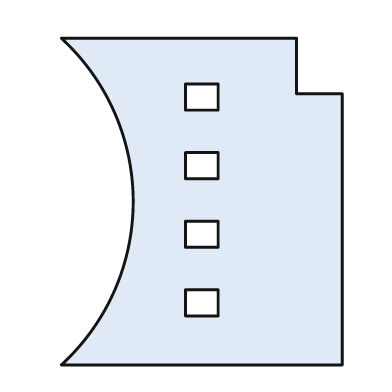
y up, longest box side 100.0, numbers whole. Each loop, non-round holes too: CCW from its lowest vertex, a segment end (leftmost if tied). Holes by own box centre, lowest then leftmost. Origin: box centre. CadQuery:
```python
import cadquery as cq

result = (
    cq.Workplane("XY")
    .moveTo(-43.0, -50.0)
    .lineTo(43.0, -50.0)
    .lineTo(43.0, 33.0)
    .lineTo(29.0, 33.0)
    .lineTo(29.0, 50.0)
    .lineTo(-43.0, 50.0)
    .threePointArc((-21.0, 0.0), (-43.0, -50.0))
    .close()
    .moveTo(-5.0, -35.0)
    .lineTo(5.0, -35.0)
    .lineTo(5.0, -27.0)
    .lineTo(-5.0, -27.0)
    .close()
    .moveTo(-5.0, -14.0)
    .lineTo(5.0, -14.0)
    .lineTo(5.0, -6.0)
    .lineTo(-5.0, -6.0)
    .close()
    .moveTo(-5.0, 7.0)
    .lineTo(5.0, 7.0)
    .lineTo(5.0, 15.0)
    .lineTo(-5.0, 15.0)
    .close()
    .moveTo(-5.0, 28.0)
    .lineTo(5.0, 28.0)
    .lineTo(5.0, 36.0)
    .lineTo(-5.0, 36.0)
    .close()
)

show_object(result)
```